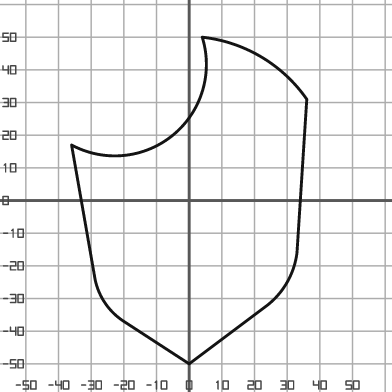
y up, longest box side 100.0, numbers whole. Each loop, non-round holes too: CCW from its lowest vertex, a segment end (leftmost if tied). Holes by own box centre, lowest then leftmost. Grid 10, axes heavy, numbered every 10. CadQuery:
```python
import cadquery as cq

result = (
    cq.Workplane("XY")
    .moveTo(0.0, -50.0)
    .lineTo(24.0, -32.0)
    .threePointArc((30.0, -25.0), (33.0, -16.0))
    .lineTo(36.0, 31.0)
    .threePointArc((22.0, 44.0), (4.0, 50.0))
    .threePointArc((-5.0, 20.0), (-36.0, 17.0))
    .lineTo(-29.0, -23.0)
    .threePointArc((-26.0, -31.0), (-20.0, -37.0))
    .close()
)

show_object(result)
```